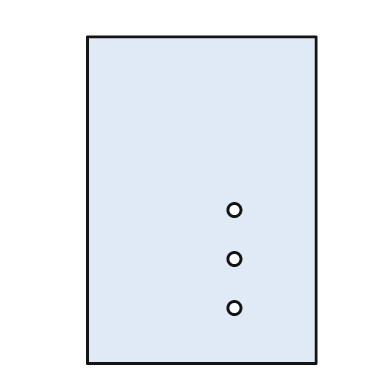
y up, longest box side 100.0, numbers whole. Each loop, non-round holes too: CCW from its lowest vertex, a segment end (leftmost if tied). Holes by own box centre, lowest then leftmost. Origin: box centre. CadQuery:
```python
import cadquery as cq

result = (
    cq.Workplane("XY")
    .moveTo(-35.0, -50.0)
    .lineTo(35.0, -50.0)
    .lineTo(35.0, 50.0)
    .lineTo(-35.0, 50.0)
    .close()
    .moveTo(10.0, -33.0)
    .circle(2.0)
    .moveTo(10.0, -18.0)
    .circle(2.0)
    .moveTo(10.0, -3.0)
    .circle(2.0)
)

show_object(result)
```